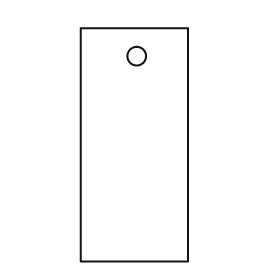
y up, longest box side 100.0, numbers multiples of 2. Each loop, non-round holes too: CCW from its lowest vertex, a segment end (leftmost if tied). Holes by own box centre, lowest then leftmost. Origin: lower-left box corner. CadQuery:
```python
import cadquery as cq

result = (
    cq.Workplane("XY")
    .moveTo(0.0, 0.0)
    .lineTo(46.0, 0.0)
    .lineTo(46.0, 100.0)
    .lineTo(0.0, 100.0)
    .close()
    .moveTo(24.0, 88.0)
    .circle(4.0)
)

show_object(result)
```